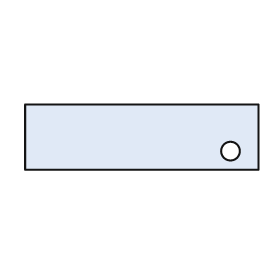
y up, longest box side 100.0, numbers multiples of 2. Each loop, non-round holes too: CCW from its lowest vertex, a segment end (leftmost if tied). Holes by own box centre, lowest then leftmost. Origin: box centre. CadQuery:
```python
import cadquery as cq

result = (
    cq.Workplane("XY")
    .moveTo(-50.0, -14.0)
    .lineTo(50.0, -14.0)
    .lineTo(50.0, 14.0)
    .lineTo(-50.0, 14.0)
    .close()
    .moveTo(38.0, -6.0)
    .circle(4.0)
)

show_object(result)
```